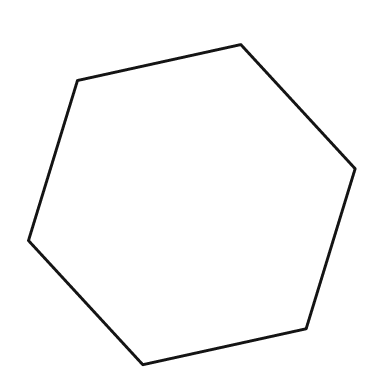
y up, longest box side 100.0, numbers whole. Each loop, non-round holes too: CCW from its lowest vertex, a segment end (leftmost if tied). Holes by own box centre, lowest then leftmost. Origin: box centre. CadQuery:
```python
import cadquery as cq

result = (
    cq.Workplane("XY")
    .moveTo(-15.0, -49.0)
    .lineTo(35.0, -38.0)
    .lineTo(50.0, 11.0)
    .lineTo(15.0, 49.0)
    .lineTo(-35.0, 38.0)
    .lineTo(-50.0, -11.0)
    .close()
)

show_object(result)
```